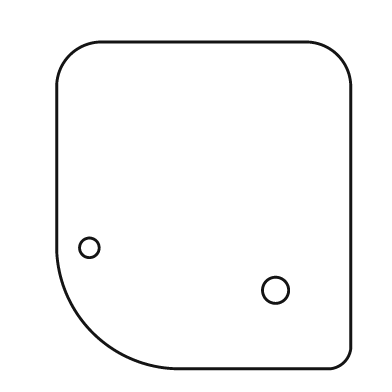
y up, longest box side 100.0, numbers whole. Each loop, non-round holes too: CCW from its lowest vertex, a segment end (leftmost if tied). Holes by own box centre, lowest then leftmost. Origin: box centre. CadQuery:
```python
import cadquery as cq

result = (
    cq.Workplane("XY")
    .moveTo(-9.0, -50.0)
    .lineTo(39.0, -50.0)
    .threePointArc((43.0, -48.0), (45.0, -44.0))
    .lineTo(45.0, 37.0)
    .threePointArc((41.0, 46.0), (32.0, 50.0))
    .lineTo(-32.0, 50.0)
    .threePointArc((-41.0, 46.0), (-45.0, 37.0))
    .lineTo(-45.0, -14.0)
    .threePointArc((-34.0, -39.0), (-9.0, -50.0))
    .close()
    .moveTo(22.0, -26.0)
    .circle(4.0)
    .moveTo(-35.0, -13.0)
    .circle(3.0)
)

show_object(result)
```